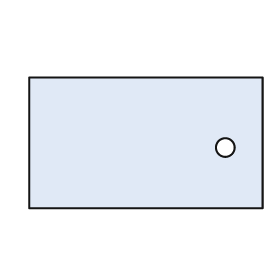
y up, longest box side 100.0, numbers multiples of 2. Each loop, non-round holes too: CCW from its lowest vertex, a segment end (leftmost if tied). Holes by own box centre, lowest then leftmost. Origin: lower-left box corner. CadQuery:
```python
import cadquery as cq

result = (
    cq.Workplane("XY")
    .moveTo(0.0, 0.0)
    .lineTo(100.0, 0.0)
    .lineTo(100.0, 56.0)
    .lineTo(0.0, 56.0)
    .close()
    .moveTo(84.0, 26.0)
    .circle(4.0)
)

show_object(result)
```